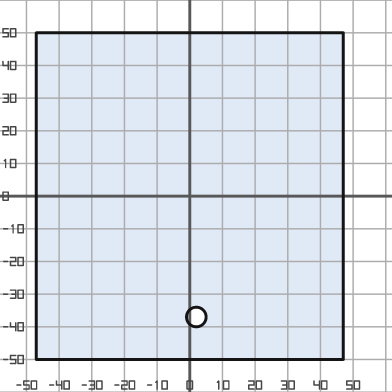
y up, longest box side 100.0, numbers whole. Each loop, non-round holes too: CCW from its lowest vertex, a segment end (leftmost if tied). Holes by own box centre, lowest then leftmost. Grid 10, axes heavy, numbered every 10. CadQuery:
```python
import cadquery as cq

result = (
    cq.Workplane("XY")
    .moveTo(-47.0, -50.0)
    .lineTo(47.0, -50.0)
    .lineTo(47.0, 50.0)
    .lineTo(-47.0, 50.0)
    .close()
    .moveTo(2.0, -37.0)
    .circle(3.0)
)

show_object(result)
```